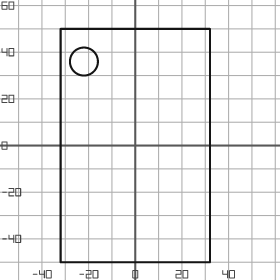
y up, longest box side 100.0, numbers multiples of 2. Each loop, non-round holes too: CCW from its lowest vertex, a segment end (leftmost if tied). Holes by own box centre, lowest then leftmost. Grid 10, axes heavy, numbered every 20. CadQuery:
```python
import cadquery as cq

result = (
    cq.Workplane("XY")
    .moveTo(-32.0, -50.0)
    .lineTo(32.0, -50.0)
    .lineTo(32.0, 50.0)
    .lineTo(-32.0, 50.0)
    .close()
    .moveTo(-22.0, 36.0)
    .circle(6.0)
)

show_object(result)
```